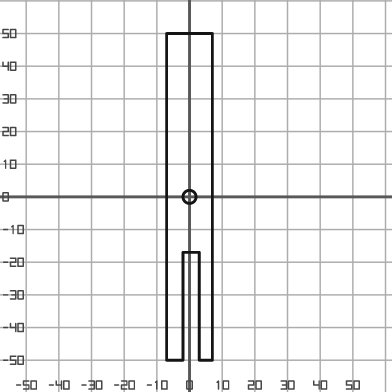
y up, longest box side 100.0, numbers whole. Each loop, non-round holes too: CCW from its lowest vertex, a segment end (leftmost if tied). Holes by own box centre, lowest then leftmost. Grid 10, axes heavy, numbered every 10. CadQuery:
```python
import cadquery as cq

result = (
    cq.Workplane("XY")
    .moveTo(-7.0, -50.0)
    .lineTo(-2.0, -50.0)
    .lineTo(-2.0, -17.0)
    .lineTo(3.0, -17.0)
    .lineTo(3.0, -50.0)
    .lineTo(7.0, -50.0)
    .lineTo(7.0, 50.0)
    .lineTo(-7.0, 50.0)
    .close()
    .moveTo(0.0, 0.0)
    .circle(2.0)
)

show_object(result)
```